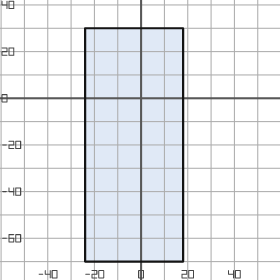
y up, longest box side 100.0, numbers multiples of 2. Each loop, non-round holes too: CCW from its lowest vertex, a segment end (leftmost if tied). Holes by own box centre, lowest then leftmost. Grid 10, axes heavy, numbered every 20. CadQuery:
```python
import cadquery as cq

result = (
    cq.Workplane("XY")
    .moveTo(-24.0, -70.0)
    .lineTo(18.0, -70.0)
    .lineTo(18.0, 30.0)
    .lineTo(-24.0, 30.0)
    .close()
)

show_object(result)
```